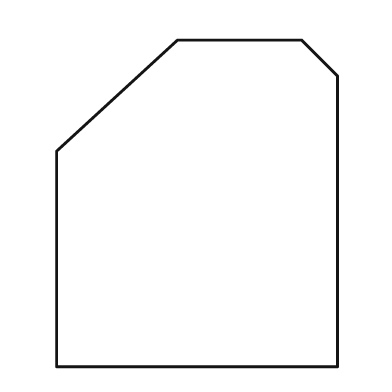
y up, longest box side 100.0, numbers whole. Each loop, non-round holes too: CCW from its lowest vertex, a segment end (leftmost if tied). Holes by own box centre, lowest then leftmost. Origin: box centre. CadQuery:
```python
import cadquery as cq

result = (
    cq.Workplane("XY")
    .moveTo(-43.0, -50.0)
    .lineTo(43.0, -50.0)
    .lineTo(43.0, 39.0)
    .lineTo(32.0, 50.0)
    .lineTo(-6.0, 50.0)
    .lineTo(-43.0, 16.0)
    .close()
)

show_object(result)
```